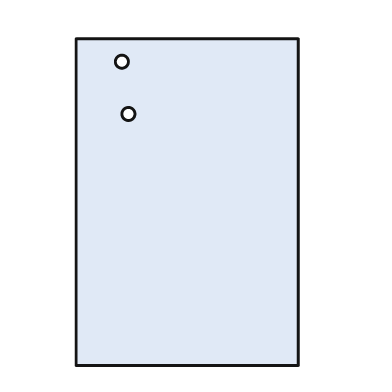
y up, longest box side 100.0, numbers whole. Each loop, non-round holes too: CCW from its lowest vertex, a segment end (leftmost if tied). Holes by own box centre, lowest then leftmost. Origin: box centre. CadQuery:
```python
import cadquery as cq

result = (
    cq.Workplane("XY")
    .moveTo(-34.0, -50.0)
    .lineTo(34.0, -50.0)
    .lineTo(34.0, 50.0)
    .lineTo(-34.0, 50.0)
    .close()
    .moveTo(-18.0, 27.0)
    .circle(2.0)
    .moveTo(-20.0, 43.0)
    .circle(2.0)
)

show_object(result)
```